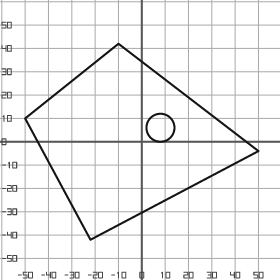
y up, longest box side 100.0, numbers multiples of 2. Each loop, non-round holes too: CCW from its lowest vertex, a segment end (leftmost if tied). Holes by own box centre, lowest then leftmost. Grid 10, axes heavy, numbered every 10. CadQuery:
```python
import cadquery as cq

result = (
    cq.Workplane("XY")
    .moveTo(-22.0, -42.0)
    .lineTo(50.0, -4.0)
    .lineTo(-10.0, 42.0)
    .lineTo(-50.0, 10.0)
    .close()
    .moveTo(8.0, 6.0)
    .circle(6.0)
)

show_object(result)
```